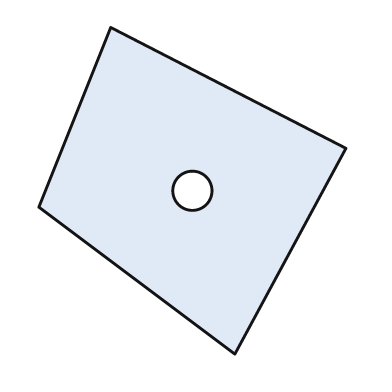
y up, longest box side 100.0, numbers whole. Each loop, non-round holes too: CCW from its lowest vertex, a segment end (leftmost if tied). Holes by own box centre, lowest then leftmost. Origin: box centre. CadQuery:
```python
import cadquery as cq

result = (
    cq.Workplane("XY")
    .moveTo(13.0, -50.0)
    .lineTo(47.0, 13.0)
    .lineTo(-25.0, 50.0)
    .lineTo(-47.0, -5.0)
    .close()
    .moveTo(0.0, 0.0)
    .circle(6.0)
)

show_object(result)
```